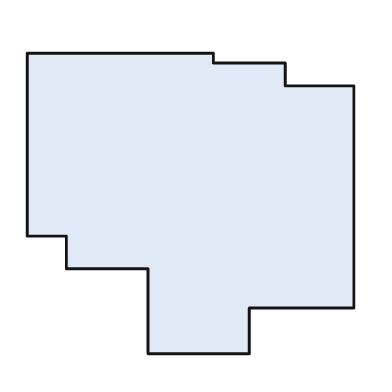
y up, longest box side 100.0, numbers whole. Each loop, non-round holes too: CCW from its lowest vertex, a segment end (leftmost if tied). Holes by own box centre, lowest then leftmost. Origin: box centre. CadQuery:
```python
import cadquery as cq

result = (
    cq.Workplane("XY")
    .moveTo(-13.0, -46.0)
    .lineTo(18.0, -46.0)
    .lineTo(18.0, -32.0)
    .lineTo(50.0, -32.0)
    .lineTo(50.0, 36.0)
    .lineTo(29.0, 36.0)
    .lineTo(29.0, 43.0)
    .lineTo(7.0, 43.0)
    .lineTo(7.0, 46.0)
    .lineTo(-50.0, 46.0)
    .lineTo(-50.0, -10.0)
    .lineTo(-38.0, -10.0)
    .lineTo(-38.0, -20.0)
    .lineTo(-13.0, -20.0)
    .close()
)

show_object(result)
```